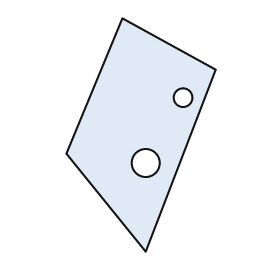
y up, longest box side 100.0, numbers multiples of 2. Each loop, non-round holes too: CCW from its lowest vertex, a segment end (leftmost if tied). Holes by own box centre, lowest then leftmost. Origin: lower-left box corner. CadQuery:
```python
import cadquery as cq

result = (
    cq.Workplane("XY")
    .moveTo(34.0, 0.0)
    .lineTo(64.0, 78.0)
    .lineTo(24.0, 100.0)
    .lineTo(0.0, 42.0)
    .close()
    .moveTo(34.0, 38.0)
    .circle(6.0)
    .moveTo(50.0, 66.0)
    .circle(4.0)
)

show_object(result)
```